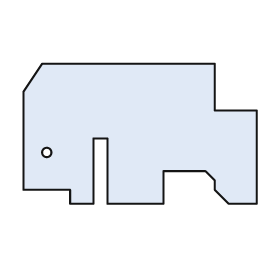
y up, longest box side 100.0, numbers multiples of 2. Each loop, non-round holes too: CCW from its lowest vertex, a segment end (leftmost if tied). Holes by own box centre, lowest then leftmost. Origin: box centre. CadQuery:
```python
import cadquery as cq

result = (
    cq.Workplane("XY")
    .moveTo(-30.0, -30.0)
    .lineTo(-20.0, -30.0)
    .lineTo(-20.0, -2.0)
    .lineTo(-14.0, -2.0)
    .lineTo(-14.0, -30.0)
    .lineTo(10.0, -30.0)
    .lineTo(10.0, -16.0)
    .lineTo(28.0, -16.0)
    .lineTo(32.0, -20.0)
    .lineTo(32.0, -24.0)
    .lineTo(38.0, -30.0)
    .lineTo(50.0, -30.0)
    .lineTo(50.0, 10.0)
    .lineTo(32.0, 10.0)
    .lineTo(32.0, 30.0)
    .lineTo(-42.0, 30.0)
    .lineTo(-50.0, 18.0)
    .lineTo(-50.0, -24.0)
    .lineTo(-30.0, -24.0)
    .close()
    .moveTo(-40.0, -8.0)
    .circle(2.0)
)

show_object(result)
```